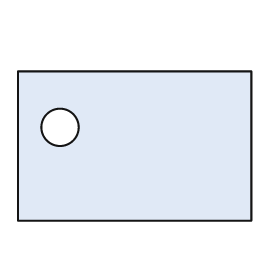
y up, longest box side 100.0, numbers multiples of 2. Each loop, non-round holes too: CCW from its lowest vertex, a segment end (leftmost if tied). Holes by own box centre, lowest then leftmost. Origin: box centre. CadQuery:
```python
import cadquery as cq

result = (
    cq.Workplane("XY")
    .moveTo(-50.0, -32.0)
    .lineTo(50.0, -32.0)
    .lineTo(50.0, 32.0)
    .lineTo(-50.0, 32.0)
    .close()
    .moveTo(-32.0, 8.0)
    .circle(8.0)
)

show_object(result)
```